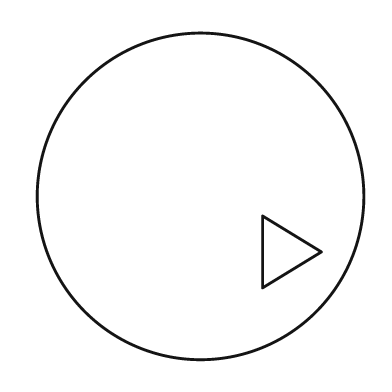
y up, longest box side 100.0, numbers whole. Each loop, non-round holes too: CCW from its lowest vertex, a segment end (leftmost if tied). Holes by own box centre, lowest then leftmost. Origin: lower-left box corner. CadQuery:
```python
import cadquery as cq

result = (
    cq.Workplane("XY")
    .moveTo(50.0, 50.0)
    .circle(50.0)
    .moveTo(69.0, 22.0)
    .lineTo(87.0, 33.0)
    .lineTo(69.0, 44.0)
    .close()
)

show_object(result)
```